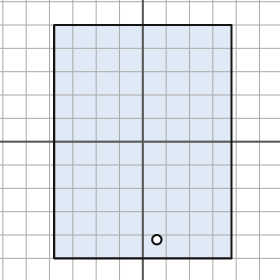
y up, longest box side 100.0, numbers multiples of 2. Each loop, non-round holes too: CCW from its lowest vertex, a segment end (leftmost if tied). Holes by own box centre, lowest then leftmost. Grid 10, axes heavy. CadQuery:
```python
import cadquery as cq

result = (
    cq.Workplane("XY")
    .moveTo(-38.0, -50.0)
    .lineTo(38.0, -50.0)
    .lineTo(38.0, 50.0)
    .lineTo(-38.0, 50.0)
    .close()
    .moveTo(6.0, -42.0)
    .circle(2.0)
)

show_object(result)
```